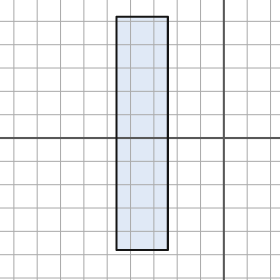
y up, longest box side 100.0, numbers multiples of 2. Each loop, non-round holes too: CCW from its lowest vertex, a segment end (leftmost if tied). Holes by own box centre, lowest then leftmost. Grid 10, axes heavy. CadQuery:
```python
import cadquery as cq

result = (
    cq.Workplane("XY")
    .moveTo(-46.0, -48.0)
    .lineTo(-24.0, -48.0)
    .lineTo(-24.0, 52.0)
    .lineTo(-46.0, 52.0)
    .close()
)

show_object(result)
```